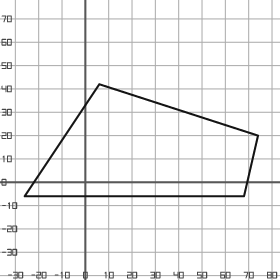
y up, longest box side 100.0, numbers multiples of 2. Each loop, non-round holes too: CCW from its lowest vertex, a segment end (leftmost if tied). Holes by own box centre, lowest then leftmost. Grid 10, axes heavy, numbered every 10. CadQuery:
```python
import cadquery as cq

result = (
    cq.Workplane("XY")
    .moveTo(-26.0, -6.0)
    .lineTo(68.0, -6.0)
    .lineTo(74.0, 20.0)
    .lineTo(6.0, 42.0)
    .close()
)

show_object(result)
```